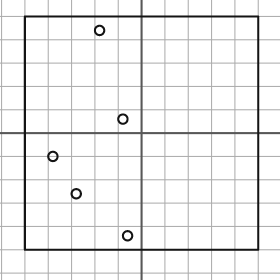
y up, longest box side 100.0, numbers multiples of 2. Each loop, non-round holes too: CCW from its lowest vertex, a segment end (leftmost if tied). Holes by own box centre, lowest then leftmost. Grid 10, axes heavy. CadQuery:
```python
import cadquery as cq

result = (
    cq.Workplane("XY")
    .moveTo(-50.0, -50.0)
    .lineTo(50.0, -50.0)
    .lineTo(50.0, 50.0)
    .lineTo(-50.0, 50.0)
    .close()
    .moveTo(-6.0, -44.0)
    .circle(2.0)
    .moveTo(-28.0, -26.0)
    .circle(2.0)
    .moveTo(-38.0, -10.0)
    .circle(2.0)
    .moveTo(-8.0, 6.0)
    .circle(2.0)
    .moveTo(-18.0, 44.0)
    .circle(2.0)
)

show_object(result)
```